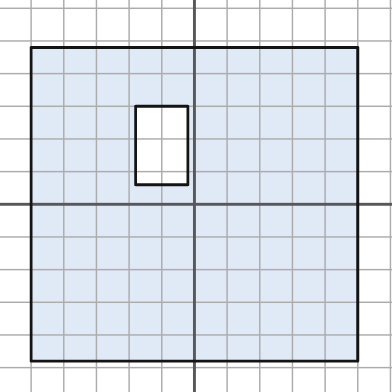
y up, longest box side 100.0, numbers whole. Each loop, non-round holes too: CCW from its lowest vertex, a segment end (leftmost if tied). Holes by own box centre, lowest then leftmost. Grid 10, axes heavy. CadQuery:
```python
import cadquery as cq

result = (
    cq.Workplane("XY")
    .moveTo(-50.0, -48.0)
    .lineTo(50.0, -48.0)
    .lineTo(50.0, 48.0)
    .lineTo(-50.0, 48.0)
    .close()
    .moveTo(-18.0, 6.0)
    .lineTo(-2.0, 6.0)
    .lineTo(-2.0, 30.0)
    .lineTo(-18.0, 30.0)
    .close()
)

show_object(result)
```